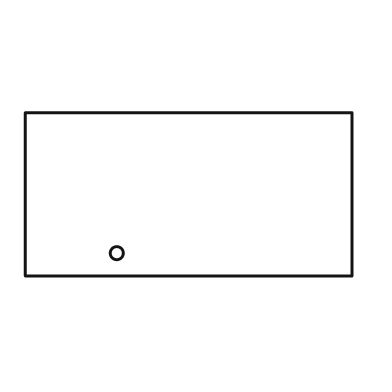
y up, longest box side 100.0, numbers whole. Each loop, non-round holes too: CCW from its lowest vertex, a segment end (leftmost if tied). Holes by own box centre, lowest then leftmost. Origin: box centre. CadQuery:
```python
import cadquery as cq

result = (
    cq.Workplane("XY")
    .moveTo(-50.0, -25.0)
    .lineTo(50.0, -25.0)
    .lineTo(50.0, 25.0)
    .lineTo(-50.0, 25.0)
    .close()
    .moveTo(-22.0, -18.0)
    .circle(2.0)
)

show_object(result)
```